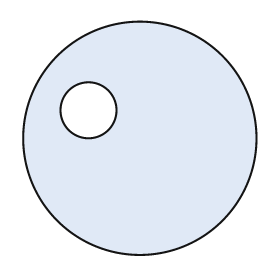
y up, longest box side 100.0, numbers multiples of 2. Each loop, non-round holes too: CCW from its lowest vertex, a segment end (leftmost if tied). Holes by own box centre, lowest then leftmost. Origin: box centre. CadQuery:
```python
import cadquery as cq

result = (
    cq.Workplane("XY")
    .moveTo(0.0, 0.0)
    .circle(50.0)
    .moveTo(-22.0, 12.0)
    .circle(12.0)
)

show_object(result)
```